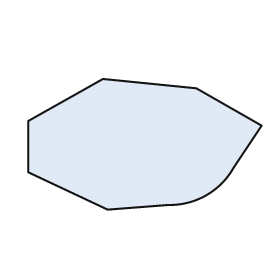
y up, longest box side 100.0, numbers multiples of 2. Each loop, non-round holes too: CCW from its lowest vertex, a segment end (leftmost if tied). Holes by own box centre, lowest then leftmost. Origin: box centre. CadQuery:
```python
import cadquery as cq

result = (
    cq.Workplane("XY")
    .moveTo(-16.0, -28.0)
    .lineTo(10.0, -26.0)
    .threePointArc((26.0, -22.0), (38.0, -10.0))
    .lineTo(50.0, 8.0)
    .lineTo(22.0, 24.0)
    .lineTo(-18.0, 28.0)
    .lineTo(-50.0, 10.0)
    .lineTo(-50.0, -12.0)
    .close()
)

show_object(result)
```